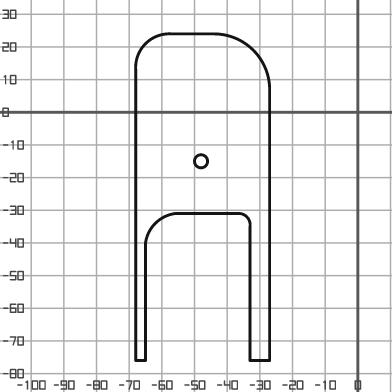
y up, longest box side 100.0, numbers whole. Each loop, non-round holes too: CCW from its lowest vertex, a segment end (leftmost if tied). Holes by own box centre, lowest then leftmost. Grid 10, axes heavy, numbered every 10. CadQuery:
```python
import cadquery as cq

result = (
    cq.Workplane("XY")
    .moveTo(-68.0, -76.0)
    .lineTo(-65.0, -76.0)
    .lineTo(-65.0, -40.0)
    .threePointArc((-62.0, -34.0), (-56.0, -31.0))
    .lineTo(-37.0, -31.0)
    .threePointArc((-34.0, -32.0), (-33.0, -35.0))
    .lineTo(-33.0, -76.0)
    .lineTo(-27.0, -76.0)
    .lineTo(-27.0, 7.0)
    .threePointArc((-32.0, 19.0), (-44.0, 24.0))
    .lineTo(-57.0, 24.0)
    .threePointArc((-65.0, 21.0), (-68.0, 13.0))
    .close()
    .moveTo(-48.0, -15.0)
    .circle(2.0)
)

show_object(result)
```